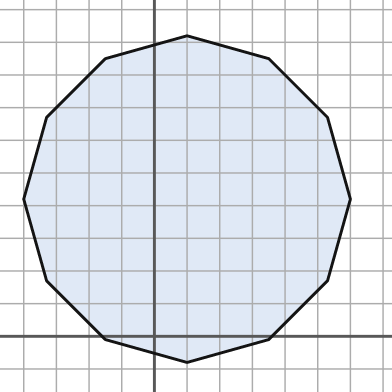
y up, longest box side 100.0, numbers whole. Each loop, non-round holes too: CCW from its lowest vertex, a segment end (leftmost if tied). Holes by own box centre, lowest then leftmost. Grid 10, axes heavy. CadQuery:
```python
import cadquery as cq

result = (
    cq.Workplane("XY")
    .moveTo(10.0, -8.0)
    .lineTo(35.0, -1.0)
    .lineTo(53.0, 17.0)
    .lineTo(60.0, 42.0)
    .lineTo(53.0, 67.0)
    .lineTo(35.0, 85.0)
    .lineTo(10.0, 92.0)
    .lineTo(-15.0, 85.0)
    .lineTo(-33.0, 67.0)
    .lineTo(-40.0, 42.0)
    .lineTo(-33.0, 17.0)
    .lineTo(-15.0, -1.0)
    .close()
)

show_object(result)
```